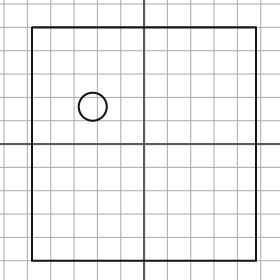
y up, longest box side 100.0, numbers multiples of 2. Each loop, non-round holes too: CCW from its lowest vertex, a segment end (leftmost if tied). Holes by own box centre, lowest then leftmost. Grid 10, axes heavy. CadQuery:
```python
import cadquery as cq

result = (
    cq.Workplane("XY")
    .moveTo(-48.0, -50.0)
    .lineTo(48.0, -50.0)
    .lineTo(48.0, 50.0)
    .lineTo(-48.0, 50.0)
    .close()
    .moveTo(-22.0, 16.0)
    .circle(6.0)
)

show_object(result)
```